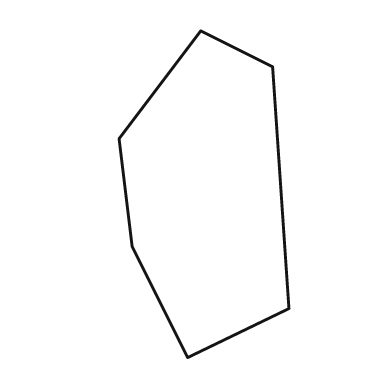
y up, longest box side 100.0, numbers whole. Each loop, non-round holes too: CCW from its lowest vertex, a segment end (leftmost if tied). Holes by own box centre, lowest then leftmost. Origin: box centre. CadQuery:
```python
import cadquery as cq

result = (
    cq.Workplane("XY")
    .moveTo(-5.0, -50.0)
    .lineTo(26.0, -35.0)
    .lineTo(21.0, 39.0)
    .lineTo(-1.0, 50.0)
    .lineTo(-26.0, 17.0)
    .lineTo(-22.0, -16.0)
    .close()
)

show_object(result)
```